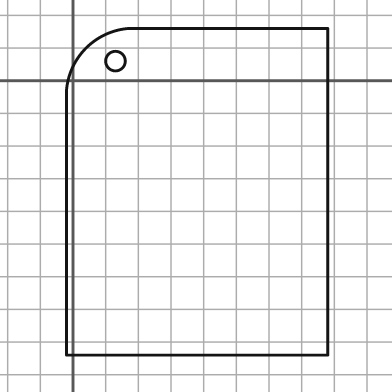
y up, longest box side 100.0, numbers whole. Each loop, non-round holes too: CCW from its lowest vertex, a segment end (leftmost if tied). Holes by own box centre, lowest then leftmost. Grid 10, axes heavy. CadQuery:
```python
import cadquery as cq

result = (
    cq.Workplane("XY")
    .moveTo(-2.0, -84.0)
    .lineTo(78.0, -84.0)
    .lineTo(78.0, 16.0)
    .lineTo(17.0, 16.0)
    .threePointArc((4.0, 10.0), (-2.0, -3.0))
    .close()
    .moveTo(13.0, 6.0)
    .circle(3.0)
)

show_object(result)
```